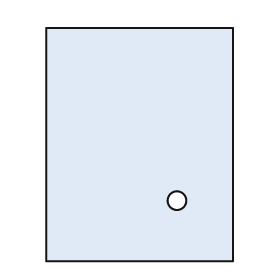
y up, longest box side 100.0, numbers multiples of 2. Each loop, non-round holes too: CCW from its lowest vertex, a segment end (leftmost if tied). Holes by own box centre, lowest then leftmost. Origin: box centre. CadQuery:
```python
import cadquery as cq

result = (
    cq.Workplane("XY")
    .moveTo(-40.0, -50.0)
    .lineTo(40.0, -50.0)
    .lineTo(40.0, 50.0)
    .lineTo(-40.0, 50.0)
    .close()
    .moveTo(16.0, -24.0)
    .circle(4.0)
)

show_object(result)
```